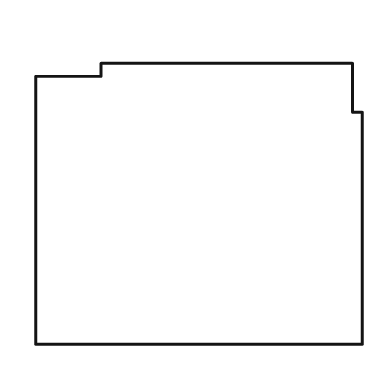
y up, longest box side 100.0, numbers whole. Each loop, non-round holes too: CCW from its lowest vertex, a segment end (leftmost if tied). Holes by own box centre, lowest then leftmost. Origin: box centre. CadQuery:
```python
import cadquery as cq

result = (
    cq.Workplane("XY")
    .moveTo(-50.0, -43.0)
    .lineTo(50.0, -43.0)
    .lineTo(50.0, 28.0)
    .lineTo(47.0, 28.0)
    .lineTo(47.0, 43.0)
    .lineTo(-30.0, 43.0)
    .lineTo(-30.0, 39.0)
    .lineTo(-50.0, 39.0)
    .close()
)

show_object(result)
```